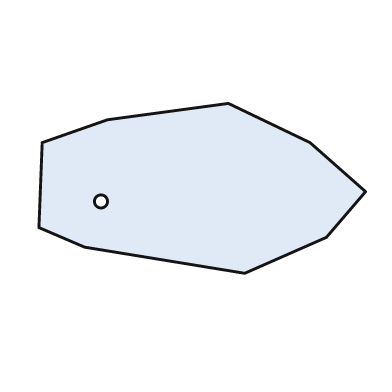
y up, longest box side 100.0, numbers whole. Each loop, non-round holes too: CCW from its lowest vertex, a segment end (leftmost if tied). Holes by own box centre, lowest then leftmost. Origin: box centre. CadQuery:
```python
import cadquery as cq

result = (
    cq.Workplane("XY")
    .moveTo(13.0, -26.0)
    .lineTo(38.0, -15.0)
    .lineTo(50.0, -1.0)
    .lineTo(33.0, 14.0)
    .lineTo(8.0, 26.0)
    .lineTo(-29.0, 21.0)
    .lineTo(-49.0, 14.0)
    .lineTo(-50.0, -12.0)
    .lineTo(-36.0, -18.0)
    .close()
    .moveTo(-31.0, -4.0)
    .circle(2.0)
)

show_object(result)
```